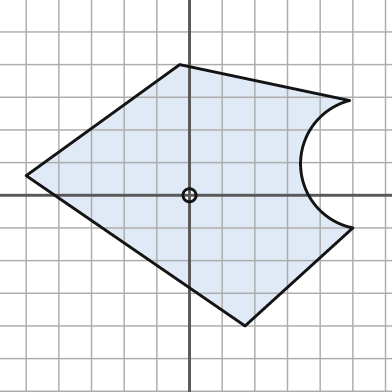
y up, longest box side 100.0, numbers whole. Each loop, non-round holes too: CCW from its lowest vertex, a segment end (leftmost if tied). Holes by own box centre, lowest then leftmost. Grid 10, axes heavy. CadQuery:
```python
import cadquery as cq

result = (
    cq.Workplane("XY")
    .moveTo(17.0, -40.0)
    .lineTo(50.0, -10.0)
    .threePointArc((34.0, 9.0), (49.0, 29.0))
    .lineTo(-3.0, 40.0)
    .lineTo(-50.0, 6.0)
    .close()
    .moveTo(0.0, 0.0)
    .circle(2.0)
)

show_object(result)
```